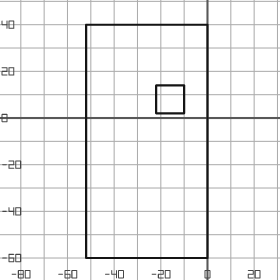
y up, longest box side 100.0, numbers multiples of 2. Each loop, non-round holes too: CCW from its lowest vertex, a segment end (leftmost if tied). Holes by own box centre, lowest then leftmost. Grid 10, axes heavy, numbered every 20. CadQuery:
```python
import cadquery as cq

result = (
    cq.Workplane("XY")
    .moveTo(-52.0, -60.0)
    .lineTo(0.0, -60.0)
    .lineTo(0.0, 40.0)
    .lineTo(-52.0, 40.0)
    .close()
    .moveTo(-22.0, 2.0)
    .lineTo(-10.0, 2.0)
    .lineTo(-10.0, 14.0)
    .lineTo(-22.0, 14.0)
    .close()
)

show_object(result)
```